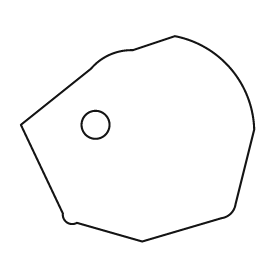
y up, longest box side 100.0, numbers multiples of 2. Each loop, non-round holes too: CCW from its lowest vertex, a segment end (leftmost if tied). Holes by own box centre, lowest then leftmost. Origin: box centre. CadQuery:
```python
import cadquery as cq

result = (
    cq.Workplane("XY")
    .moveTo(2.0, -44.0)
    .lineTo(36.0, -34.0)
    .threePointArc((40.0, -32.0), (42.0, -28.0))
    .lineTo(50.0, 4.0)
    .threePointArc((40.0, 30.0), (16.0, 44.0))
    .lineTo(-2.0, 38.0)
    .threePointArc((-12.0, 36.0), (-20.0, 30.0))
    .lineTo(-50.0, 6.0)
    .lineTo(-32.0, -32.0)
    .threePointArc((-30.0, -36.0), (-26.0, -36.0))
    .close()
    .moveTo(-18.0, 6.0)
    .circle(6.0)
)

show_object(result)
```